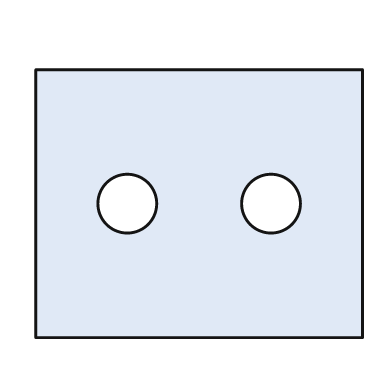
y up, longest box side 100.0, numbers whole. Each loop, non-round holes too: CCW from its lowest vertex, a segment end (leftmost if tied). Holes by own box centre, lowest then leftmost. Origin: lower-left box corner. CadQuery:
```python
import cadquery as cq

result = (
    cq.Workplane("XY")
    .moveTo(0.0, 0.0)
    .lineTo(100.0, 0.0)
    .lineTo(100.0, 82.0)
    .lineTo(0.0, 82.0)
    .close()
    .moveTo(28.0, 41.0)
    .circle(9.0)
    .moveTo(72.0, 41.0)
    .circle(9.0)
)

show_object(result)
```